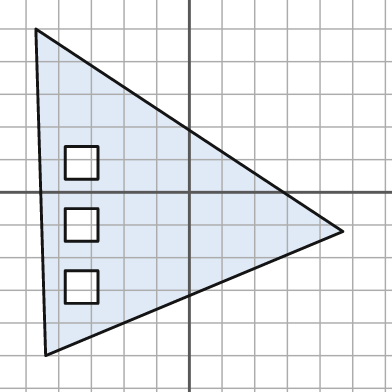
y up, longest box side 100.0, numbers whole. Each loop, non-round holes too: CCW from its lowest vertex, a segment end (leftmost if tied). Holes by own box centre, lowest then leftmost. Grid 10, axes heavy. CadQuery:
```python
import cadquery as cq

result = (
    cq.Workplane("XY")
    .moveTo(-44.0, -50.0)
    .lineTo(47.0, -12.0)
    .lineTo(-47.0, 50.0)
    .close()
    .moveTo(-38.0, -34.0)
    .lineTo(-28.0, -34.0)
    .lineTo(-28.0, -24.0)
    .lineTo(-38.0, -24.0)
    .close()
    .moveTo(-38.0, -15.0)
    .lineTo(-28.0, -15.0)
    .lineTo(-28.0, -5.0)
    .lineTo(-38.0, -5.0)
    .close()
    .moveTo(-38.0, 4.0)
    .lineTo(-28.0, 4.0)
    .lineTo(-28.0, 14.0)
    .lineTo(-38.0, 14.0)
    .close()
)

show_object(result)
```